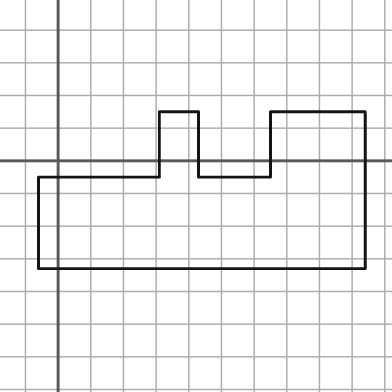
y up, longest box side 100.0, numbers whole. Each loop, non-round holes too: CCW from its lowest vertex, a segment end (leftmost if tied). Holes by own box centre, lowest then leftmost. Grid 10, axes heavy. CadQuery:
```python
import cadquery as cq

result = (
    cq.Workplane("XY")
    .moveTo(-6.0, -33.0)
    .lineTo(94.0, -33.0)
    .lineTo(94.0, 15.0)
    .lineTo(65.0, 15.0)
    .lineTo(65.0, -5.0)
    .lineTo(43.0, -5.0)
    .lineTo(43.0, 15.0)
    .lineTo(31.0, 15.0)
    .lineTo(31.0, -5.0)
    .lineTo(-6.0, -5.0)
    .close()
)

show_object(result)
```